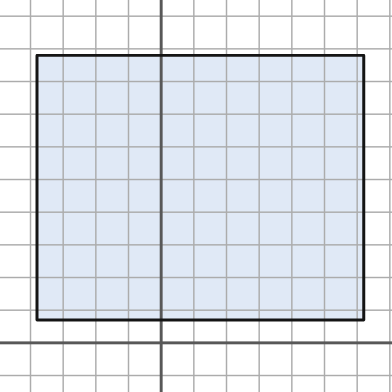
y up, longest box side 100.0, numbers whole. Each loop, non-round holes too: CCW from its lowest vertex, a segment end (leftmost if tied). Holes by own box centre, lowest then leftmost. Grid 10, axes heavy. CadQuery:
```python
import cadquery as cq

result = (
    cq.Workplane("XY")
    .moveTo(-38.0, 7.0)
    .lineTo(62.0, 7.0)
    .lineTo(62.0, 88.0)
    .lineTo(-38.0, 88.0)
    .close()
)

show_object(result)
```